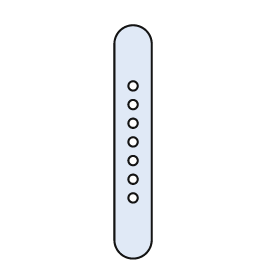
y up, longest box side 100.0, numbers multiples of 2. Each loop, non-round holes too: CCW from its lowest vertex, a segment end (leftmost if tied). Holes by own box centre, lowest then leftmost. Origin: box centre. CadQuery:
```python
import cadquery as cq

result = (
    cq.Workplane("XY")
    .moveTo(-8.0, -42.0)
    .threePointArc((0.0, -50.0), (8.0, -42.0))
    .lineTo(8.0, 42.0)
    .threePointArc((0.0, 50.0), (-8.0, 42.0))
    .close()
    .moveTo(0.0, -24.0)
    .circle(2.0)
    .moveTo(0.0, -16.0)
    .circle(2.0)
    .moveTo(0.0, -8.0)
    .circle(2.0)
    .moveTo(0.0, 0.0)
    .circle(2.0)
    .moveTo(0.0, 8.0)
    .circle(2.0)
    .moveTo(0.0, 16.0)
    .circle(2.0)
    .moveTo(0.0, 24.0)
    .circle(2.0)
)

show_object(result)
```